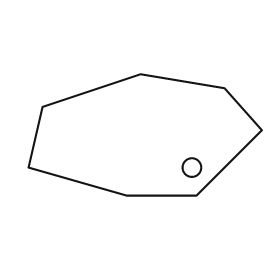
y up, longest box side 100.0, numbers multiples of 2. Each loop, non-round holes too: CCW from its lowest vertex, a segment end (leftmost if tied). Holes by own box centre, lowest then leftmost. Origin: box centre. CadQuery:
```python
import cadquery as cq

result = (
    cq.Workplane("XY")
    .moveTo(-8.0, -26.0)
    .lineTo(22.0, -26.0)
    .lineTo(50.0, 2.0)
    .lineTo(34.0, 20.0)
    .lineTo(-2.0, 26.0)
    .lineTo(-44.0, 12.0)
    .lineTo(-50.0, -14.0)
    .close()
    .moveTo(20.0, -14.0)
    .circle(4.0)
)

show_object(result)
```